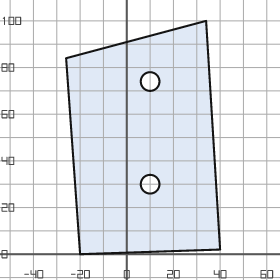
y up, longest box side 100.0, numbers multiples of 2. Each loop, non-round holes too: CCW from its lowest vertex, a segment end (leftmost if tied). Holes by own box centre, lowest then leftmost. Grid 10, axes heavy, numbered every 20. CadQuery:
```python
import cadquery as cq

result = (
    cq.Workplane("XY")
    .moveTo(-20.0, 0.0)
    .lineTo(40.0, 2.0)
    .lineTo(34.0, 100.0)
    .lineTo(-26.0, 84.0)
    .close()
    .moveTo(10.0, 30.0)
    .circle(4.0)
    .moveTo(10.0, 74.0)
    .circle(4.0)
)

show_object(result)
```